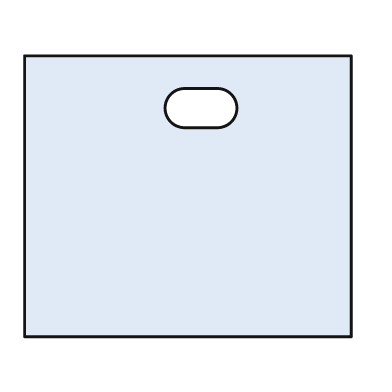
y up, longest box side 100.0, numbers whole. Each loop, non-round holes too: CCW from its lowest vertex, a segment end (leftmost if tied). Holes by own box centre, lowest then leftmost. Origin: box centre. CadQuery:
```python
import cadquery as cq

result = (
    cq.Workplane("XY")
    .moveTo(-50.0, -43.0)
    .lineTo(50.0, -43.0)
    .lineTo(50.0, 43.0)
    .lineTo(-50.0, 43.0)
    .close()
    .moveTo(-1.0, 21.0)
    .lineTo(9.0, 21.0)
    .threePointArc((15.0, 27.0), (9.0, 33.0))
    .lineTo(-1.0, 33.0)
    .threePointArc((-7.0, 27.0), (-1.0, 21.0))
    .close()
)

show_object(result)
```